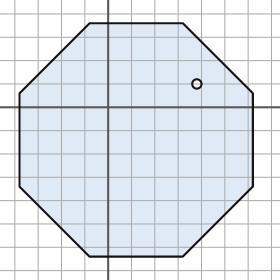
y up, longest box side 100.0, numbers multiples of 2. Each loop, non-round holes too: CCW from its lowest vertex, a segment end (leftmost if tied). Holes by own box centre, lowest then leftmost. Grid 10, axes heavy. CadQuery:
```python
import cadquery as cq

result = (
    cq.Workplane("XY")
    .moveTo(-8.0, -64.0)
    .lineTo(32.0, -64.0)
    .lineTo(62.0, -34.0)
    .lineTo(62.0, 6.0)
    .lineTo(32.0, 36.0)
    .lineTo(-8.0, 36.0)
    .lineTo(-38.0, 6.0)
    .lineTo(-38.0, -34.0)
    .close()
    .moveTo(38.0, 10.0)
    .circle(2.0)
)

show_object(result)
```